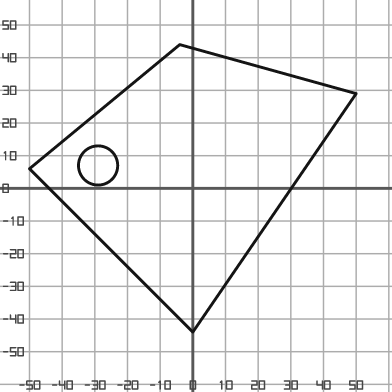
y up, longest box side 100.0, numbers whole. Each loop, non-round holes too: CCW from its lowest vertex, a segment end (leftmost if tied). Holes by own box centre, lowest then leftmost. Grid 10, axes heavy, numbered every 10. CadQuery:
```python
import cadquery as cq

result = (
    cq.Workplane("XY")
    .moveTo(0.0, -44.0)
    .lineTo(50.0, 29.0)
    .lineTo(-4.0, 44.0)
    .lineTo(-50.0, 6.0)
    .close()
    .moveTo(-29.0, 7.0)
    .circle(6.0)
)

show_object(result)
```